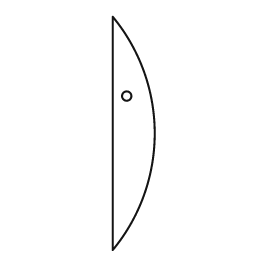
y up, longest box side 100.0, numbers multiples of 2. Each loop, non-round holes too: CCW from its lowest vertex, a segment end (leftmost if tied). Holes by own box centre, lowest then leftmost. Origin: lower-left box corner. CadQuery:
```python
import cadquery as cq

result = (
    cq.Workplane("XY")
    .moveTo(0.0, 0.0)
    .threePointArc((18.0, 50.0), (0.0, 100.0))
    .close()
    .moveTo(6.0, 66.0)
    .circle(2.0)
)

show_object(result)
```